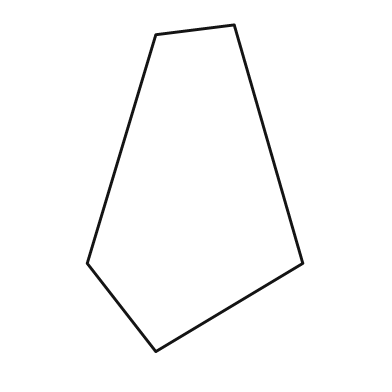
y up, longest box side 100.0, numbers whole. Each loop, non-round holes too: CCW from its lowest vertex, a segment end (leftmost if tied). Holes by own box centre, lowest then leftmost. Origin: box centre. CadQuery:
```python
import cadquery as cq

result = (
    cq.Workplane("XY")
    .moveTo(-12.0, -50.0)
    .lineTo(33.0, -23.0)
    .lineTo(12.0, 50.0)
    .lineTo(-12.0, 47.0)
    .lineTo(-33.0, -23.0)
    .close()
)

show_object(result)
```